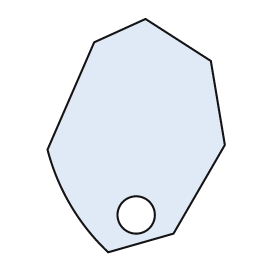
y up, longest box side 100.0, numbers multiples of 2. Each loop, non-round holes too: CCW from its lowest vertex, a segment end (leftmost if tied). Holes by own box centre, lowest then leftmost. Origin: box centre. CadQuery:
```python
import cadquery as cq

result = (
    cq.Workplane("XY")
    .moveTo(-12.0, -50.0)
    .lineTo(16.0, -42.0)
    .lineTo(38.0, -4.0)
    .lineTo(32.0, 32.0)
    .lineTo(4.0, 50.0)
    .lineTo(-18.0, 40.0)
    .lineTo(-38.0, -6.0)
    .threePointArc((-28.0, -30.0), (-12.0, -50.0))
    .close()
    .moveTo(0.0, -34.0)
    .circle(8.0)
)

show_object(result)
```